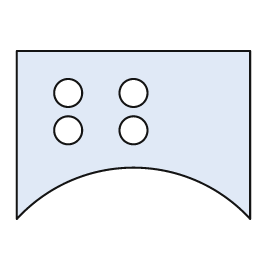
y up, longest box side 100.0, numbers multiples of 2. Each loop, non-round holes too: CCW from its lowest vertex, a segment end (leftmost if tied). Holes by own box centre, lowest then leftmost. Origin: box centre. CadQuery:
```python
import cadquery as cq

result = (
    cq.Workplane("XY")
    .moveTo(-50.0, -36.0)
    .threePointArc((0.0, -14.0), (50.0, -36.0))
    .lineTo(50.0, 36.0)
    .lineTo(-50.0, 36.0)
    .close()
    .moveTo(-28.0, 2.0)
    .circle(6.0)
    .moveTo(0.0, 2.0)
    .circle(6.0)
    .moveTo(-28.0, 18.0)
    .circle(6.0)
    .moveTo(0.0, 18.0)
    .circle(6.0)
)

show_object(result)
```